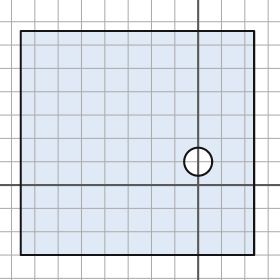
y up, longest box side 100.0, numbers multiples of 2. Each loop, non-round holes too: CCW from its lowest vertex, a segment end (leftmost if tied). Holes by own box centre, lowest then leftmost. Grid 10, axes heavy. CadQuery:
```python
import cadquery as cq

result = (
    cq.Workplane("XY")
    .moveTo(-76.0, -30.0)
    .lineTo(24.0, -30.0)
    .lineTo(24.0, 66.0)
    .lineTo(-76.0, 66.0)
    .close()
    .moveTo(0.0, 10.0)
    .circle(6.0)
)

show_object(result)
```